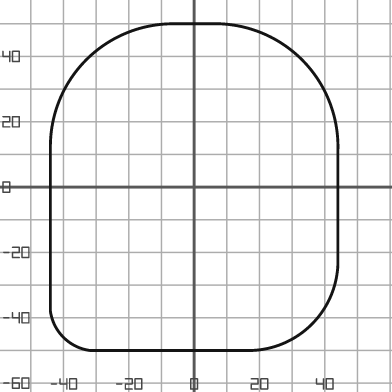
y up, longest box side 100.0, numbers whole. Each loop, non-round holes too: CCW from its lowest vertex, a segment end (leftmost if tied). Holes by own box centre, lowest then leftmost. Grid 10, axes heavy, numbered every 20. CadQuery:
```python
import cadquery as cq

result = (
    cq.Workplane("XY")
    .moveTo(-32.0, -50.0)
    .lineTo(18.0, -50.0)
    .threePointArc((36.0, -42.0), (44.0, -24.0))
    .lineTo(44.0, 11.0)
    .threePointArc((33.0, 39.0), (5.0, 50.0))
    .lineTo(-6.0, 50.0)
    .threePointArc((-33.0, 39.0), (-44.0, 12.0))
    .lineTo(-44.0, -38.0)
    .threePointArc((-40.0, -46.0), (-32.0, -50.0))
    .close()
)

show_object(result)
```